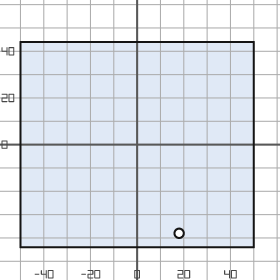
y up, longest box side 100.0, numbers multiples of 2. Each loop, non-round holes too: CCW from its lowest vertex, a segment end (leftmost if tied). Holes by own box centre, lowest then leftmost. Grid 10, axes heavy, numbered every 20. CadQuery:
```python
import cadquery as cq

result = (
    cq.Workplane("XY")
    .moveTo(-50.0, -44.0)
    .lineTo(50.0, -44.0)
    .lineTo(50.0, 44.0)
    .lineTo(-50.0, 44.0)
    .close()
    .moveTo(18.0, -38.0)
    .circle(2.0)
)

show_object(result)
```